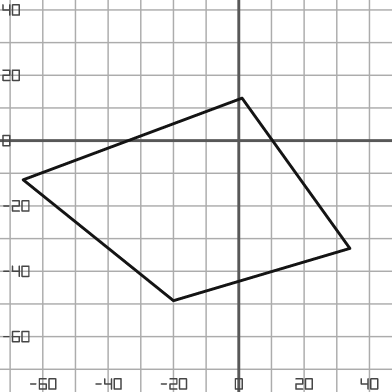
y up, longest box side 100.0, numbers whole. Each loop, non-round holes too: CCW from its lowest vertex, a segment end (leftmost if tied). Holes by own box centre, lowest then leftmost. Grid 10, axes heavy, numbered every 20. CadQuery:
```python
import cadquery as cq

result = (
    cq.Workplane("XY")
    .moveTo(-20.0, -49.0)
    .lineTo(34.0, -33.0)
    .lineTo(1.0, 13.0)
    .lineTo(-66.0, -12.0)
    .close()
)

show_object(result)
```